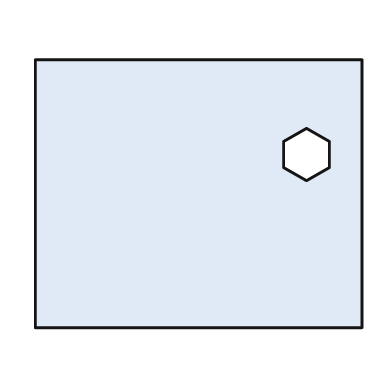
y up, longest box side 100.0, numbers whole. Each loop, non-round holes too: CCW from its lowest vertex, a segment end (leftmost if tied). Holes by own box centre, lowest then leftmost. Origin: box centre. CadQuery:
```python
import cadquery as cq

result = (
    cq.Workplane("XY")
    .moveTo(-50.0, -41.0)
    .lineTo(50.0, -41.0)
    .lineTo(50.0, 41.0)
    .lineTo(-50.0, 41.0)
    .close()
    .moveTo(33.0, 4.0)
    .lineTo(40.0, 8.0)
    .lineTo(40.0, 16.0)
    .lineTo(33.0, 20.0)
    .lineTo(26.0, 16.0)
    .lineTo(26.0, 8.0)
    .close()
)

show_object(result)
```